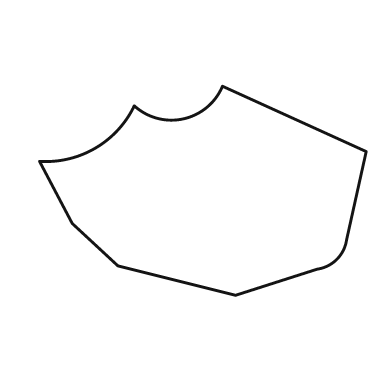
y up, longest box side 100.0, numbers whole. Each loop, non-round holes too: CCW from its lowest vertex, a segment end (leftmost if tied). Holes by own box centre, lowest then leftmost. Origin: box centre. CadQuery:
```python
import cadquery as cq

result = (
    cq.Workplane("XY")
    .moveTo(10.0, -32.0)
    .lineTo(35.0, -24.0)
    .threePointArc((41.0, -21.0), (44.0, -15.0))
    .lineTo(50.0, 12.0)
    .lineTo(6.0, 32.0)
    .threePointArc((-6.0, 22.0), (-21.0, 26.0))
    .threePointArc((-33.0, 13.0), (-50.0, 9.0))
    .lineTo(-40.0, -10.0)
    .lineTo(-26.0, -23.0)
    .close()
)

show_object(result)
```